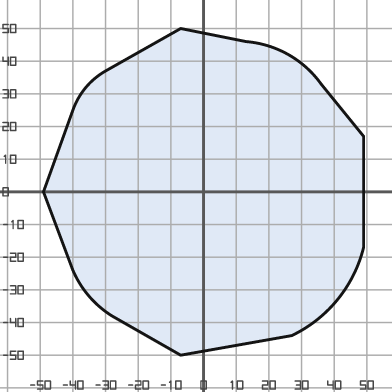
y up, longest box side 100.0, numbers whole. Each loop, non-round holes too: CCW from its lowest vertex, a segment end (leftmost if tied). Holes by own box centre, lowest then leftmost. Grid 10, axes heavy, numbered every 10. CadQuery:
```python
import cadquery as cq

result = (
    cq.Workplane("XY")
    .moveTo(-7.0, -50.0)
    .lineTo(27.0, -44.0)
    .threePointArc((41.0, -33.0), (49.0, -17.0))
    .lineTo(49.0, 17.0)
    .lineTo(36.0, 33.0)
    .threePointArc((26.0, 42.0), (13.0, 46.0))
    .lineTo(-7.0, 50.0)
    .lineTo(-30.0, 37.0)
    .threePointArc((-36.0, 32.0), (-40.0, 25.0))
    .lineTo(-49.0, 0.0)
    .lineTo(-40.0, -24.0)
    .threePointArc((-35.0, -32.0), (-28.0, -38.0))
    .close()
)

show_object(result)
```